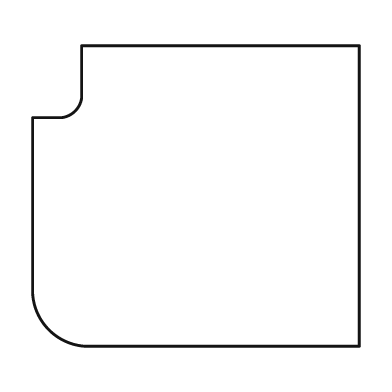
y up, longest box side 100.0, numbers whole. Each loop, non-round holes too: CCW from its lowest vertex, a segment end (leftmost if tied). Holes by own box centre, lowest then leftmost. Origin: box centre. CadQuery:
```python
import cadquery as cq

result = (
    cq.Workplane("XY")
    .moveTo(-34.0, -46.0)
    .lineTo(50.0, -46.0)
    .lineTo(50.0, 46.0)
    .lineTo(-35.0, 46.0)
    .lineTo(-35.0, 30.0)
    .threePointArc((-37.0, 26.0), (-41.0, 24.0))
    .lineTo(-50.0, 24.0)
    .lineTo(-50.0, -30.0)
    .threePointArc((-45.0, -41.0), (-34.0, -46.0))
    .close()
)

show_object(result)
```